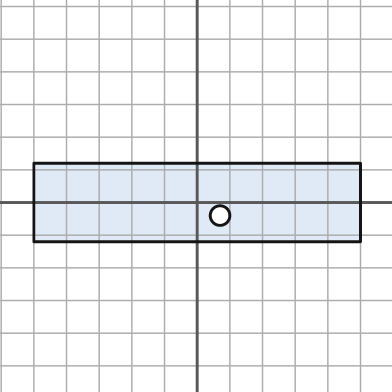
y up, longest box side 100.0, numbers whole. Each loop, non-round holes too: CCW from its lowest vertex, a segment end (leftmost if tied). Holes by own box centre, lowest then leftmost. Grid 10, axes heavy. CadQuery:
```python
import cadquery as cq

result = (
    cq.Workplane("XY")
    .moveTo(-50.0, -12.0)
    .lineTo(50.0, -12.0)
    .lineTo(50.0, 12.0)
    .lineTo(-50.0, 12.0)
    .close()
    .moveTo(7.0, -4.0)
    .circle(3.0)
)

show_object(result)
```